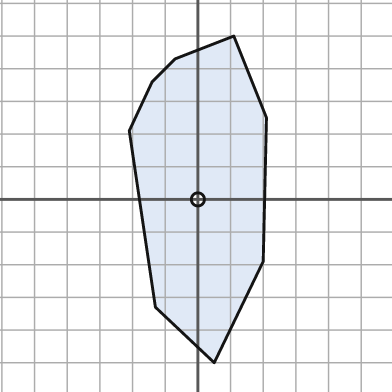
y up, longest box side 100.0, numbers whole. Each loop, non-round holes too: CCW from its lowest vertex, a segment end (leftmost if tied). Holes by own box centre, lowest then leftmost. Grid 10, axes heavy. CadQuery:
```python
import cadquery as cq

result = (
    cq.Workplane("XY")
    .moveTo(5.0, -50.0)
    .lineTo(20.0, -19.0)
    .lineTo(21.0, 25.0)
    .lineTo(11.0, 50.0)
    .lineTo(-7.0, 43.0)
    .lineTo(-14.0, 36.0)
    .lineTo(-21.0, 21.0)
    .lineTo(-13.0, -33.0)
    .close()
    .moveTo(0.0, 0.0)
    .circle(2.0)
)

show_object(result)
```